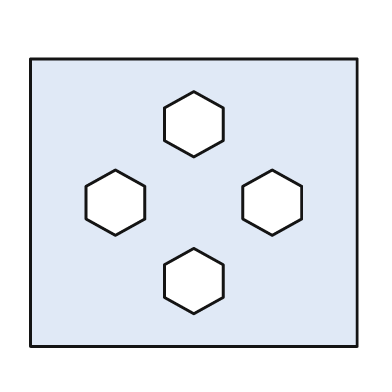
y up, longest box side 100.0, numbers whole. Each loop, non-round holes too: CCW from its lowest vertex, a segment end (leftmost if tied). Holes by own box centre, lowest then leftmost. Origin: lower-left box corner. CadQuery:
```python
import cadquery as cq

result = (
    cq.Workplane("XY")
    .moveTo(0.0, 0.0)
    .lineTo(100.0, 0.0)
    .lineTo(100.0, 88.0)
    .lineTo(0.0, 88.0)
    .close()
    .moveTo(50.0, 10.0)
    .lineTo(59.0, 15.0)
    .lineTo(59.0, 25.0)
    .lineTo(50.0, 30.0)
    .lineTo(41.0, 25.0)
    .lineTo(41.0, 15.0)
    .close()
    .moveTo(26.0, 34.0)
    .lineTo(35.0, 39.0)
    .lineTo(35.0, 49.0)
    .lineTo(26.0, 54.0)
    .lineTo(17.0, 49.0)
    .lineTo(17.0, 39.0)
    .close()
    .moveTo(74.0, 34.0)
    .lineTo(83.0, 39.0)
    .lineTo(83.0, 49.0)
    .lineTo(74.0, 54.0)
    .lineTo(65.0, 49.0)
    .lineTo(65.0, 39.0)
    .close()
    .moveTo(50.0, 58.0)
    .lineTo(59.0, 63.0)
    .lineTo(59.0, 73.0)
    .lineTo(50.0, 78.0)
    .lineTo(41.0, 73.0)
    .lineTo(41.0, 63.0)
    .close()
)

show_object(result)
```